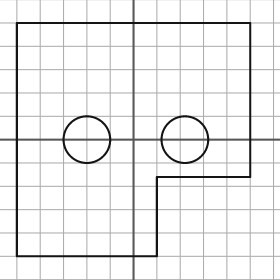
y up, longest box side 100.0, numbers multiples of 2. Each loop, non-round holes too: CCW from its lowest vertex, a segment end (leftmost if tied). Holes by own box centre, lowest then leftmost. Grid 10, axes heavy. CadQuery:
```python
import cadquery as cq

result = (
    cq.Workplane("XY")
    .moveTo(-50.0, -50.0)
    .lineTo(10.0, -50.0)
    .lineTo(10.0, -16.0)
    .lineTo(50.0, -16.0)
    .lineTo(50.0, 50.0)
    .lineTo(-50.0, 50.0)
    .close()
    .moveTo(-20.0, 0.0)
    .circle(10.0)
    .moveTo(22.0, 0.0)
    .circle(10.0)
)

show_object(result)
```